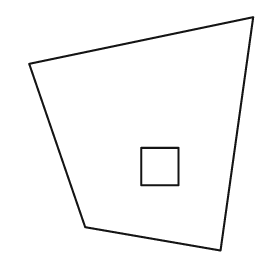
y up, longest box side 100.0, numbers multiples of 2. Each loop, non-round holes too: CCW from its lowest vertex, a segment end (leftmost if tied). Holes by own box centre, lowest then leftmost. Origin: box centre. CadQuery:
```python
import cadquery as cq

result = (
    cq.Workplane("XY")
    .moveTo(34.0, -50.0)
    .lineTo(48.0, 50.0)
    .lineTo(-48.0, 30.0)
    .lineTo(-24.0, -40.0)
    .close()
    .moveTo(0.0, -22.0)
    .lineTo(16.0, -22.0)
    .lineTo(16.0, -6.0)
    .lineTo(0.0, -6.0)
    .close()
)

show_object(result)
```